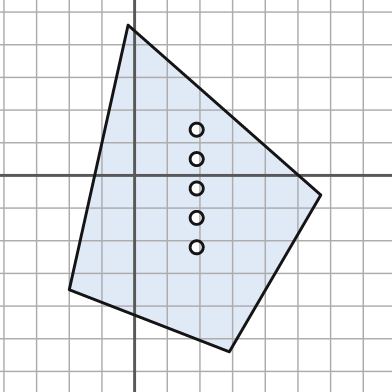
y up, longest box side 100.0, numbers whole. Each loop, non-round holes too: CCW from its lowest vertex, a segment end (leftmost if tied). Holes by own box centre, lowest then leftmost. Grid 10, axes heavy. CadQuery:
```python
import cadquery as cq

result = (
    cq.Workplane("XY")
    .moveTo(29.0, -54.0)
    .lineTo(57.0, -6.0)
    .lineTo(-2.0, 46.0)
    .lineTo(-20.0, -35.0)
    .close()
    .moveTo(19.0, -22.0)
    .circle(2.0)
    .moveTo(19.0, -13.0)
    .circle(2.0)
    .moveTo(19.0, -4.0)
    .circle(2.0)
    .moveTo(19.0, 5.0)
    .circle(2.0)
    .moveTo(19.0, 14.0)
    .circle(2.0)
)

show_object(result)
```